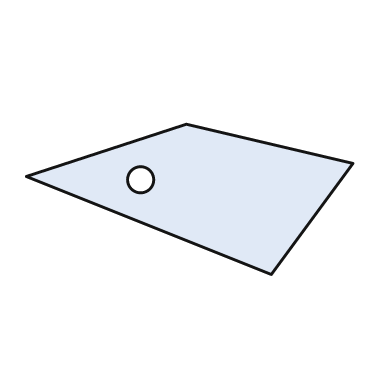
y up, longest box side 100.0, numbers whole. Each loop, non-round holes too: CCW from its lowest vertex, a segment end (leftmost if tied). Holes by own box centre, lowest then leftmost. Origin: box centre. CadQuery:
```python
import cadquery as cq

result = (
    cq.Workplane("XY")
    .moveTo(25.0, -23.0)
    .lineTo(50.0, 11.0)
    .lineTo(-1.0, 23.0)
    .lineTo(-50.0, 7.0)
    .close()
    .moveTo(-15.0, 6.0)
    .circle(4.0)
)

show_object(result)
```